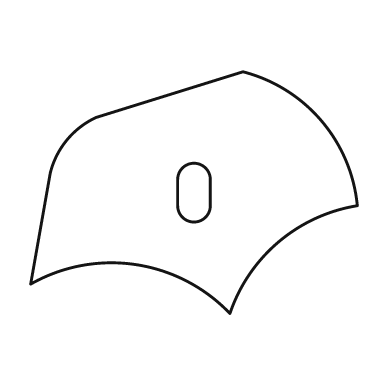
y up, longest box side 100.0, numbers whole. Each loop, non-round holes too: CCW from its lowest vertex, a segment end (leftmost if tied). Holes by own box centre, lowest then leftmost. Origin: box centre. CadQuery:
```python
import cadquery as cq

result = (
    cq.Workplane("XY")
    .moveTo(11.0, -37.0)
    .threePointArc((26.0, -15.0), (50.0, -4.0))
    .threePointArc((39.0, 22.0), (15.0, 37.0))
    .lineTo(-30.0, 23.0)
    .threePointArc((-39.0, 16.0), (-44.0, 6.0))
    .lineTo(-50.0, -28.0)
    .threePointArc((-18.0, -22.0), (11.0, -37.0))
    .close()
    .moveTo(-5.0, -4.0)
    .threePointArc((0.0, -9.0), (5.0, -4.0))
    .lineTo(5.0, 4.0)
    .threePointArc((0.0, 9.0), (-5.0, 4.0))
    .close()
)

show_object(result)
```